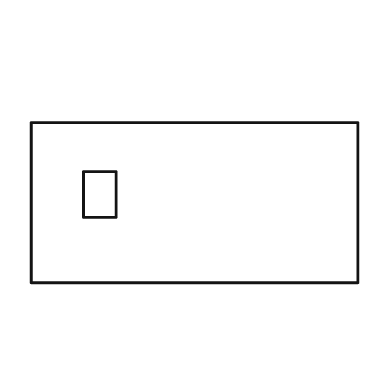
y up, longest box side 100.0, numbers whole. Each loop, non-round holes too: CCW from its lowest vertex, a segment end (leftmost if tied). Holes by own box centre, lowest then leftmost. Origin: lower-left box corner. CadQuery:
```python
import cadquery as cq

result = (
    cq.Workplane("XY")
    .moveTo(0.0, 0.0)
    .lineTo(100.0, 0.0)
    .lineTo(100.0, 49.0)
    .lineTo(0.0, 49.0)
    .close()
    .moveTo(16.0, 20.0)
    .lineTo(26.0, 20.0)
    .lineTo(26.0, 34.0)
    .lineTo(16.0, 34.0)
    .close()
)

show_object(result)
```